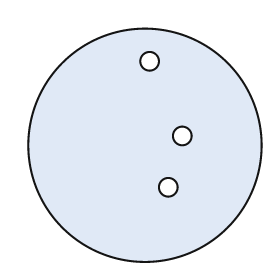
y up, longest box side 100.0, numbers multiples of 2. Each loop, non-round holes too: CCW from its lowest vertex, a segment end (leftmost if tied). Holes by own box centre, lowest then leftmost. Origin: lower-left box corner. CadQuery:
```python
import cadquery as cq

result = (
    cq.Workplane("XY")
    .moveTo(50.0, 50.0)
    .circle(50.0)
    .moveTo(60.0, 32.0)
    .circle(4.0)
    .moveTo(66.0, 54.0)
    .circle(4.0)
    .moveTo(52.0, 86.0)
    .circle(4.0)
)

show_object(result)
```